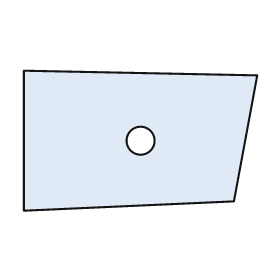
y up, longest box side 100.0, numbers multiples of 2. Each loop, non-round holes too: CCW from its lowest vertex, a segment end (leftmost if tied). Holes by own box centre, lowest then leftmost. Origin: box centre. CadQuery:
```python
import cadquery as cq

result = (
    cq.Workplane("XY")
    .moveTo(-50.0, -30.0)
    .lineTo(40.0, -26.0)
    .lineTo(50.0, 28.0)
    .lineTo(-50.0, 30.0)
    .close()
    .moveTo(0.0, 0.0)
    .circle(6.0)
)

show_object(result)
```